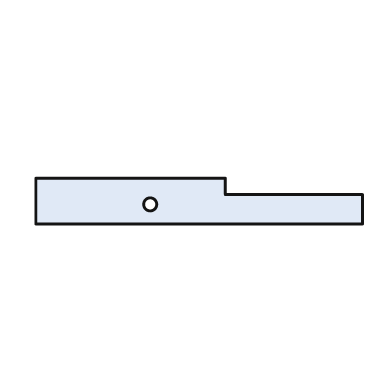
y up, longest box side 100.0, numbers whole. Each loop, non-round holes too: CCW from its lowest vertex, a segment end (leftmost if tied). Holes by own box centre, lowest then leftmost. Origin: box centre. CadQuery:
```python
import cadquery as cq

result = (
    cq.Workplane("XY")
    .moveTo(-50.0, -7.0)
    .lineTo(50.0, -7.0)
    .lineTo(50.0, 2.0)
    .lineTo(8.0, 2.0)
    .lineTo(8.0, 7.0)
    .lineTo(-50.0, 7.0)
    .close()
    .moveTo(-15.0, -1.0)
    .circle(2.0)
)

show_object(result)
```